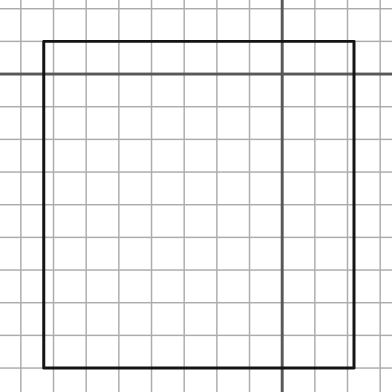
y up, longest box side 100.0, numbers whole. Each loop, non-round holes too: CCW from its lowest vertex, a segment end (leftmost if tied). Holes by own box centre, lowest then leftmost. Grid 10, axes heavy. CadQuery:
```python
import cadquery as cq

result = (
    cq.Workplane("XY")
    .moveTo(-73.0, -90.0)
    .lineTo(22.0, -90.0)
    .lineTo(22.0, 10.0)
    .lineTo(-73.0, 10.0)
    .close()
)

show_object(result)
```